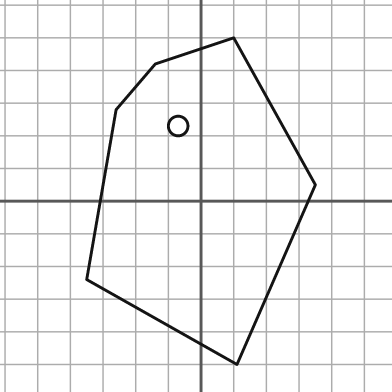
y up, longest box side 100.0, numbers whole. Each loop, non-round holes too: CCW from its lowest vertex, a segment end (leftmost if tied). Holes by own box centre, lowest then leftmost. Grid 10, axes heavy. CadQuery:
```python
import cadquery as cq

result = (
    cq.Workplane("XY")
    .moveTo(11.0, -50.0)
    .lineTo(35.0, 5.0)
    .lineTo(10.0, 50.0)
    .lineTo(-14.0, 42.0)
    .lineTo(-26.0, 28.0)
    .lineTo(-35.0, -24.0)
    .close()
    .moveTo(-7.0, 23.0)
    .circle(3.0)
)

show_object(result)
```